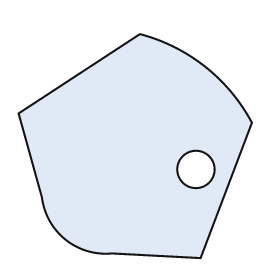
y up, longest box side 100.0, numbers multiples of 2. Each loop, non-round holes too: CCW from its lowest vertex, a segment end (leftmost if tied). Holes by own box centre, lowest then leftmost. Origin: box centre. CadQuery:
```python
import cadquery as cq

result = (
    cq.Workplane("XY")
    .moveTo(28.0, -48.0)
    .lineTo(50.0, 10.0)
    .threePointArc((30.0, 34.0), (2.0, 48.0))
    .lineTo(-50.0, 14.0)
    .lineTo(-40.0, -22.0)
    .threePointArc((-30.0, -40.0), (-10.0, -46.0))
    .close()
    .moveTo(26.0, -10.0)
    .circle(8.0)
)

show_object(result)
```